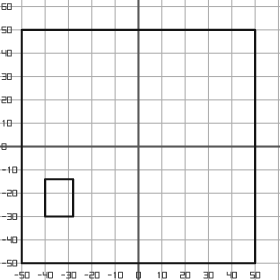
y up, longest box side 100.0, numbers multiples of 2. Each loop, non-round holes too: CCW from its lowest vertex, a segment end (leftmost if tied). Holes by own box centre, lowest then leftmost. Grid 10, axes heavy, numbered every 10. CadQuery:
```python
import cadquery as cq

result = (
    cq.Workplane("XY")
    .moveTo(-50.0, -50.0)
    .lineTo(50.0, -50.0)
    .lineTo(50.0, 50.0)
    .lineTo(-50.0, 50.0)
    .close()
    .moveTo(-40.0, -30.0)
    .lineTo(-28.0, -30.0)
    .lineTo(-28.0, -14.0)
    .lineTo(-40.0, -14.0)
    .close()
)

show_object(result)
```